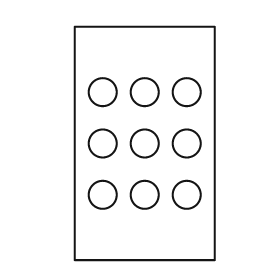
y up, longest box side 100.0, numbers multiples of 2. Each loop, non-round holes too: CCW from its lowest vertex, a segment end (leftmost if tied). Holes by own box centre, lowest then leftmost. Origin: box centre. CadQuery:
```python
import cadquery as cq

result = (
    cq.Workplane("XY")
    .moveTo(-30.0, -50.0)
    .lineTo(30.0, -50.0)
    .lineTo(30.0, 50.0)
    .lineTo(-30.0, 50.0)
    .close()
    .moveTo(-18.0, -22.0)
    .circle(6.0)
    .moveTo(0.0, -22.0)
    .circle(6.0)
    .moveTo(18.0, -22.0)
    .circle(6.0)
    .moveTo(-18.0, 0.0)
    .circle(6.0)
    .moveTo(0.0, 0.0)
    .circle(6.0)
    .moveTo(18.0, 0.0)
    .circle(6.0)
    .moveTo(-18.0, 22.0)
    .circle(6.0)
    .moveTo(0.0, 22.0)
    .circle(6.0)
    .moveTo(18.0, 22.0)
    .circle(6.0)
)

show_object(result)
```